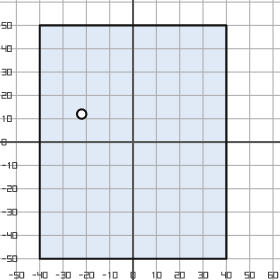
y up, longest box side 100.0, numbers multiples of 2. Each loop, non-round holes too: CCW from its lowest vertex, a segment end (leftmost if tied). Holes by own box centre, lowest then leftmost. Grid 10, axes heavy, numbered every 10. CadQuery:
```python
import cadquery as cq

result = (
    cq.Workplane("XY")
    .moveTo(-40.0, -50.0)
    .lineTo(40.0, -50.0)
    .lineTo(40.0, 50.0)
    .lineTo(-40.0, 50.0)
    .close()
    .moveTo(-22.0, 12.0)
    .circle(2.0)
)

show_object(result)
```